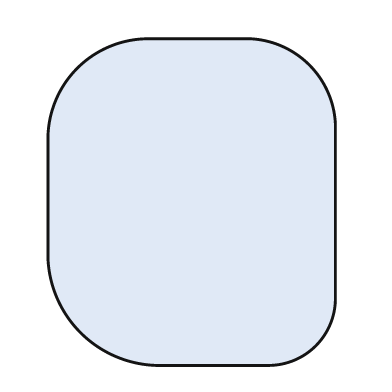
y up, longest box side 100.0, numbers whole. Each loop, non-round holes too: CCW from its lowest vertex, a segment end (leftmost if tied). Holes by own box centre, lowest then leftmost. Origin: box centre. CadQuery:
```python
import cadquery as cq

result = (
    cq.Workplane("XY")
    .moveTo(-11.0, -50.0)
    .lineTo(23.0, -50.0)
    .threePointArc((38.0, -44.0), (44.0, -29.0))
    .lineTo(44.0, 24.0)
    .threePointArc((36.0, 42.0), (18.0, 50.0))
    .lineTo(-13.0, 50.0)
    .threePointArc((-35.0, 41.0), (-44.0, 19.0))
    .lineTo(-44.0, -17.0)
    .threePointArc((-34.0, -40.0), (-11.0, -50.0))
    .close()
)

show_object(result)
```